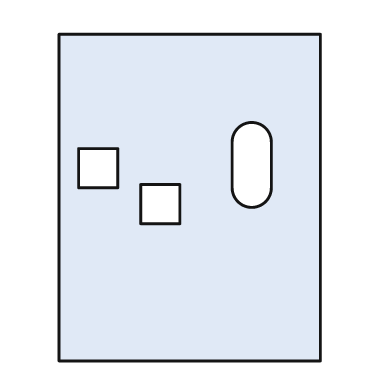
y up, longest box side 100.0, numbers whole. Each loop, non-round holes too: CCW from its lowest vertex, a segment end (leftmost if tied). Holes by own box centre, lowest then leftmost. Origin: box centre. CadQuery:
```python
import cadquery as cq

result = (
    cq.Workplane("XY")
    .moveTo(-40.0, -50.0)
    .lineTo(40.0, -50.0)
    .lineTo(40.0, 50.0)
    .lineTo(-40.0, 50.0)
    .close()
    .moveTo(-15.0, -8.0)
    .lineTo(-3.0, -8.0)
    .lineTo(-3.0, 4.0)
    .lineTo(-15.0, 4.0)
    .close()
    .moveTo(-34.0, 3.0)
    .lineTo(-22.0, 3.0)
    .lineTo(-22.0, 15.0)
    .lineTo(-34.0, 15.0)
    .close()
    .moveTo(13.0, 3.0)
    .threePointArc((19.0, -3.0), (25.0, 3.0))
    .lineTo(25.0, 17.0)
    .threePointArc((19.0, 23.0), (13.0, 17.0))
    .close()
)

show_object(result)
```